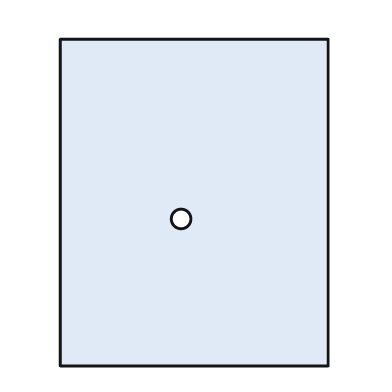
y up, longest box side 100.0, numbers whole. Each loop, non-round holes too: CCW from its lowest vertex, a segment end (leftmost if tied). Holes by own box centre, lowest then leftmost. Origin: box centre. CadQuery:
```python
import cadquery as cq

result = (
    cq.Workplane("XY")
    .moveTo(-41.0, -50.0)
    .lineTo(41.0, -50.0)
    .lineTo(41.0, 50.0)
    .lineTo(-41.0, 50.0)
    .close()
    .moveTo(-4.0, -5.0)
    .circle(3.0)
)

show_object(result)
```